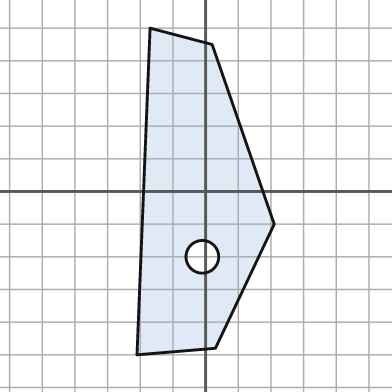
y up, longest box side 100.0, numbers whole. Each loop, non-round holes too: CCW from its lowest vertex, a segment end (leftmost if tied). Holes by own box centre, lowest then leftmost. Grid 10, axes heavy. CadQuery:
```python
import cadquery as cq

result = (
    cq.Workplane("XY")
    .moveTo(-21.0, -50.0)
    .lineTo(3.0, -48.0)
    .lineTo(21.0, -10.0)
    .lineTo(2.0, 45.0)
    .lineTo(-17.0, 50.0)
    .close()
    .moveTo(-1.0, -20.0)
    .circle(5.0)
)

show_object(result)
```